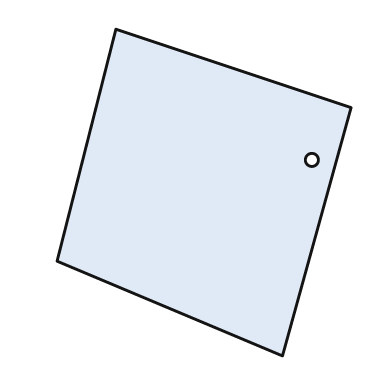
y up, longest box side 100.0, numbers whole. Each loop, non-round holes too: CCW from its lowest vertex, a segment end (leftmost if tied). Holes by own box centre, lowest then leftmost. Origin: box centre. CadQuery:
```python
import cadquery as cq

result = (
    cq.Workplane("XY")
    .moveTo(24.0, -50.0)
    .lineTo(45.0, 26.0)
    .lineTo(-27.0, 50.0)
    .lineTo(-45.0, -21.0)
    .close()
    .moveTo(33.0, 10.0)
    .circle(2.0)
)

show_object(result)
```